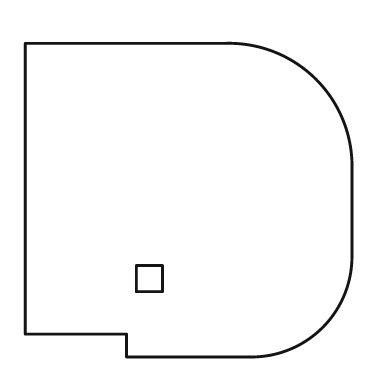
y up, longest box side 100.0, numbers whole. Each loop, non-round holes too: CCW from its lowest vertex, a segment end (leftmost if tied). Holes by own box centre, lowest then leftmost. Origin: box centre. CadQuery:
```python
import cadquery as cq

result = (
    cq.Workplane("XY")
    .moveTo(-19.0, -48.0)
    .lineTo(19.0, -48.0)
    .threePointArc((41.0, -39.0), (50.0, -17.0))
    .lineTo(50.0, 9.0)
    .threePointArc((39.0, 37.0), (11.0, 48.0))
    .lineTo(-50.0, 48.0)
    .lineTo(-50.0, -41.0)
    .lineTo(-19.0, -41.0)
    .close()
    .moveTo(-16.0, -28.0)
    .lineTo(-8.0, -28.0)
    .lineTo(-8.0, -20.0)
    .lineTo(-16.0, -20.0)
    .close()
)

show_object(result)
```